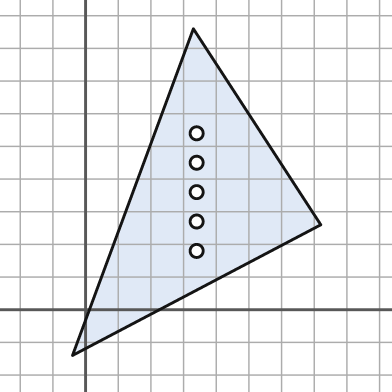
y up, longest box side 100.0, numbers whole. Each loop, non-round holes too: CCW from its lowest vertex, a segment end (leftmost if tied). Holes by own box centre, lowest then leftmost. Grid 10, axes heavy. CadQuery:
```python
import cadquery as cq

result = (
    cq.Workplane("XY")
    .moveTo(-4.0, -14.0)
    .lineTo(72.0, 26.0)
    .lineTo(33.0, 86.0)
    .close()
    .moveTo(34.0, 18.0)
    .circle(2.0)
    .moveTo(34.0, 27.0)
    .circle(2.0)
    .moveTo(34.0, 36.0)
    .circle(2.0)
    .moveTo(34.0, 45.0)
    .circle(2.0)
    .moveTo(34.0, 54.0)
    .circle(2.0)
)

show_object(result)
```